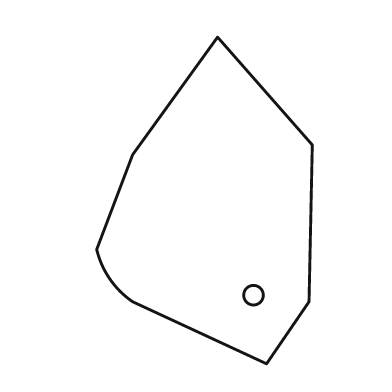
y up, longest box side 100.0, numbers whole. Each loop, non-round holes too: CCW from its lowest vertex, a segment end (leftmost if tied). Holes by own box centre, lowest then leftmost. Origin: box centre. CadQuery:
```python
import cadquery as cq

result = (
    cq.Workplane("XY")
    .moveTo(19.0, -50.0)
    .lineTo(32.0, -31.0)
    .lineTo(33.0, 17.0)
    .lineTo(4.0, 50.0)
    .lineTo(-22.0, 14.0)
    .lineTo(-33.0, -15.0)
    .threePointArc((-29.0, -24.0), (-22.0, -31.0))
    .close()
    .moveTo(15.0, -29.0)
    .circle(3.0)
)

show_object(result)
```